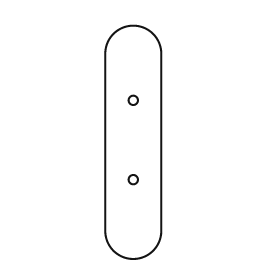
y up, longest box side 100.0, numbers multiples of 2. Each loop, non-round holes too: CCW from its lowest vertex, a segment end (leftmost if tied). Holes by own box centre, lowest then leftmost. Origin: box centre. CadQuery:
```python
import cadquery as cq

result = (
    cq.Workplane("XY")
    .moveTo(-12.0, -38.0)
    .threePointArc((0.0, -50.0), (12.0, -38.0))
    .lineTo(12.0, 38.0)
    .threePointArc((0.0, 50.0), (-12.0, 38.0))
    .close()
    .moveTo(0.0, -16.0)
    .circle(2.0)
    .moveTo(0.0, 18.0)
    .circle(2.0)
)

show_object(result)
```